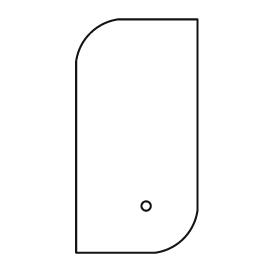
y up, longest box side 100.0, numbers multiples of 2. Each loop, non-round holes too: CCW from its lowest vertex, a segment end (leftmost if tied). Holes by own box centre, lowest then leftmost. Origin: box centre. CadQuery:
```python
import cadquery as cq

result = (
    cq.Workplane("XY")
    .moveTo(-26.0, -50.0)
    .lineTo(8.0, -50.0)
    .threePointArc((20.0, -44.0), (26.0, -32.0))
    .lineTo(26.0, 50.0)
    .lineTo(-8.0, 50.0)
    .threePointArc((-20.0, 44.0), (-26.0, 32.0))
    .close()
    .moveTo(4.0, -30.0)
    .circle(2.0)
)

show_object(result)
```